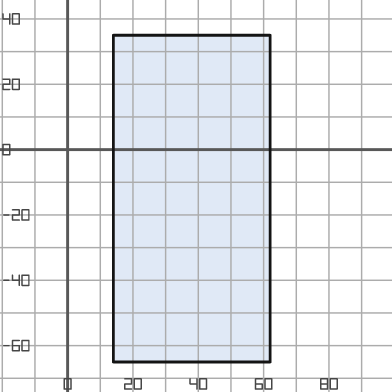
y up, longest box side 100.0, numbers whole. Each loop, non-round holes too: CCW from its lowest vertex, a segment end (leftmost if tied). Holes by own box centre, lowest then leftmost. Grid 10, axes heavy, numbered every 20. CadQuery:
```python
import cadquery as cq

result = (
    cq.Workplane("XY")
    .moveTo(14.0, -65.0)
    .lineTo(62.0, -65.0)
    .lineTo(62.0, 35.0)
    .lineTo(14.0, 35.0)
    .close()
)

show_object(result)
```